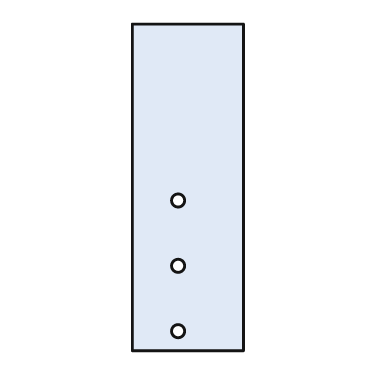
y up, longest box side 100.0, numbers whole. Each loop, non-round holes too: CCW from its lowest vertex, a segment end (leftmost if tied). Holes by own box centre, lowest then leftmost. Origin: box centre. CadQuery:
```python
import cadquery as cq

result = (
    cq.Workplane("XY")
    .moveTo(-17.0, -50.0)
    .lineTo(17.0, -50.0)
    .lineTo(17.0, 50.0)
    .lineTo(-17.0, 50.0)
    .close()
    .moveTo(-3.0, -44.0)
    .circle(2.0)
    .moveTo(-3.0, -24.0)
    .circle(2.0)
    .moveTo(-3.0, -4.0)
    .circle(2.0)
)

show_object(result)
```